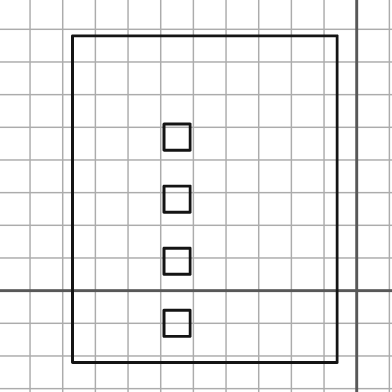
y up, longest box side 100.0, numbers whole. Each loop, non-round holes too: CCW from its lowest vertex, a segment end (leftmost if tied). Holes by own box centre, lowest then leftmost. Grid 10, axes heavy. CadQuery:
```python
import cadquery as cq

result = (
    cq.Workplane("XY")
    .moveTo(-87.0, -22.0)
    .lineTo(-6.0, -22.0)
    .lineTo(-6.0, 78.0)
    .lineTo(-87.0, 78.0)
    .close()
    .moveTo(-59.0, -14.0)
    .lineTo(-51.0, -14.0)
    .lineTo(-51.0, -6.0)
    .lineTo(-59.0, -6.0)
    .close()
    .moveTo(-59.0, 5.0)
    .lineTo(-51.0, 5.0)
    .lineTo(-51.0, 13.0)
    .lineTo(-59.0, 13.0)
    .close()
    .moveTo(-59.0, 24.0)
    .lineTo(-51.0, 24.0)
    .lineTo(-51.0, 32.0)
    .lineTo(-59.0, 32.0)
    .close()
    .moveTo(-59.0, 43.0)
    .lineTo(-51.0, 43.0)
    .lineTo(-51.0, 51.0)
    .lineTo(-59.0, 51.0)
    .close()
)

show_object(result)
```